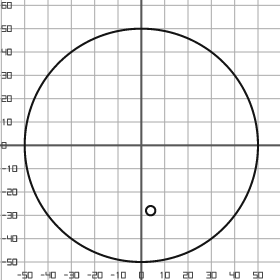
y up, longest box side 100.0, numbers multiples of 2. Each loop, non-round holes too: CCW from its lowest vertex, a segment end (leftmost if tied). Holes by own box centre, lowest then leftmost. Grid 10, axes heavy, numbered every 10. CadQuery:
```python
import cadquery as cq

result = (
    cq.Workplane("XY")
    .moveTo(0.0, 0.0)
    .circle(50.0)
    .moveTo(4.0, -28.0)
    .circle(2.0)
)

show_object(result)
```